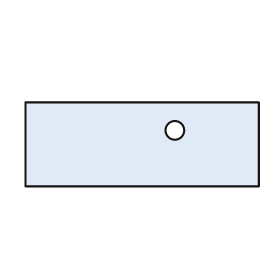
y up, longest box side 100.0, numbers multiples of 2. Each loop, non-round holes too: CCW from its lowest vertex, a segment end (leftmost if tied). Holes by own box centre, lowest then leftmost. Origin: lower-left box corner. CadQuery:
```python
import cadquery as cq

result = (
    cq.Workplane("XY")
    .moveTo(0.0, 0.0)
    .lineTo(100.0, 0.0)
    .lineTo(100.0, 36.0)
    .lineTo(0.0, 36.0)
    .close()
    .moveTo(64.0, 24.0)
    .circle(4.0)
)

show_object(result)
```